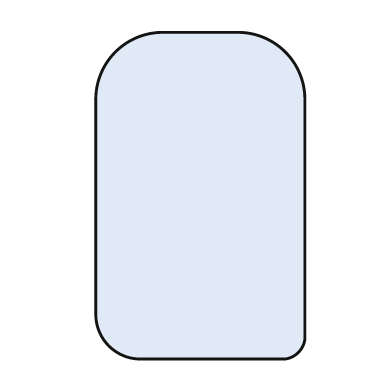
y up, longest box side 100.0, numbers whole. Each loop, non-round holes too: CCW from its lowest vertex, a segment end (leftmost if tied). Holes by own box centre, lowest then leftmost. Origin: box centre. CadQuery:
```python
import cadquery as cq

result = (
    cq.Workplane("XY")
    .moveTo(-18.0, -50.0)
    .lineTo(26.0, -50.0)
    .threePointArc((30.0, -48.0), (32.0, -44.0))
    .lineTo(32.0, 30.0)
    .threePointArc((26.0, 44.0), (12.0, 50.0))
    .lineTo(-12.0, 50.0)
    .threePointArc((-26.0, 44.0), (-32.0, 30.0))
    .lineTo(-32.0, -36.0)
    .threePointArc((-28.0, -46.0), (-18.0, -50.0))
    .close()
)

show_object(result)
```